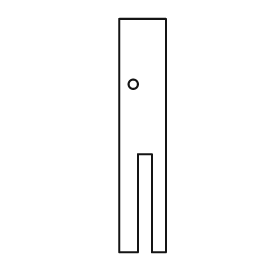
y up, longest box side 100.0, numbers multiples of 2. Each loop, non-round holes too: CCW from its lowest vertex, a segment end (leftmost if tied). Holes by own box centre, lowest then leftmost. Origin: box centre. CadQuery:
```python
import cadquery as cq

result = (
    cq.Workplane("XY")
    .moveTo(-10.0, -50.0)
    .lineTo(-2.0, -50.0)
    .lineTo(-2.0, -8.0)
    .lineTo(4.0, -8.0)
    .lineTo(4.0, -50.0)
    .lineTo(10.0, -50.0)
    .lineTo(10.0, 50.0)
    .lineTo(-10.0, 50.0)
    .close()
    .moveTo(-4.0, 22.0)
    .circle(2.0)
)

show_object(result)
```